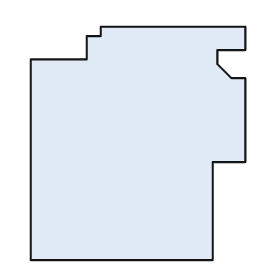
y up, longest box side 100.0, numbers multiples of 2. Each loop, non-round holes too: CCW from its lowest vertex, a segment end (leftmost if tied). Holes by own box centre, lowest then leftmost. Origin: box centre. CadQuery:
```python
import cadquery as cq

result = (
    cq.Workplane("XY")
    .moveTo(-46.0, -50.0)
    .lineTo(32.0, -50.0)
    .lineTo(32.0, -8.0)
    .lineTo(46.0, -8.0)
    .lineTo(46.0, 28.0)
    .lineTo(40.0, 28.0)
    .lineTo(34.0, 34.0)
    .lineTo(34.0, 40.0)
    .lineTo(46.0, 40.0)
    .lineTo(46.0, 50.0)
    .lineTo(-16.0, 50.0)
    .lineTo(-16.0, 46.0)
    .lineTo(-22.0, 46.0)
    .lineTo(-22.0, 36.0)
    .lineTo(-46.0, 36.0)
    .close()
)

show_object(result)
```